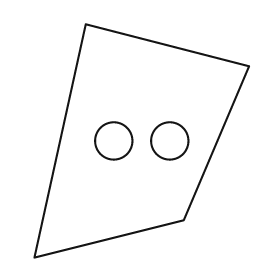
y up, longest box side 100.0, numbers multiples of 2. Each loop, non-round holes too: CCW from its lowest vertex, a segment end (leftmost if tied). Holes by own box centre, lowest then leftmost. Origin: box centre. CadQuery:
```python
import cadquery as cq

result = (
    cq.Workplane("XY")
    .moveTo(-46.0, -50.0)
    .lineTo(18.0, -34.0)
    .lineTo(46.0, 32.0)
    .lineTo(-24.0, 50.0)
    .close()
    .moveTo(-12.0, 0.0)
    .circle(8.0)
    .moveTo(12.0, 0.0)
    .circle(8.0)
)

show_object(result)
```